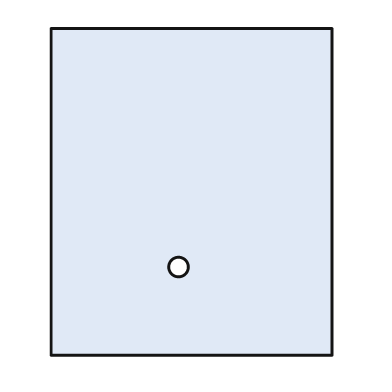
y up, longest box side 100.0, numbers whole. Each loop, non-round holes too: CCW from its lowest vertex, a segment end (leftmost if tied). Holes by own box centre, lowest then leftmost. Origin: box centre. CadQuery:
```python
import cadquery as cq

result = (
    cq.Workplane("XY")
    .moveTo(-43.0, -50.0)
    .lineTo(43.0, -50.0)
    .lineTo(43.0, 50.0)
    .lineTo(-43.0, 50.0)
    .close()
    .moveTo(-4.0, -23.0)
    .circle(3.0)
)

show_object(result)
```